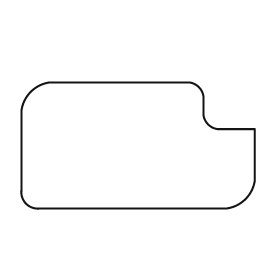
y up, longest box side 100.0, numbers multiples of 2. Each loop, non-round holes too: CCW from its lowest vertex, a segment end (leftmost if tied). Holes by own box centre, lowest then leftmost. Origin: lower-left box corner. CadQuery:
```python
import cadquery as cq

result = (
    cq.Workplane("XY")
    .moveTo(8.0, 0.0)
    .lineTo(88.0, 0.0)
    .threePointArc((96.0, 4.0), (100.0, 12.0))
    .lineTo(100.0, 34.0)
    .lineTo(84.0, 34.0)
    .threePointArc((80.0, 36.0), (78.0, 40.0))
    .lineTo(78.0, 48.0)
    .threePointArc((76.0, 52.0), (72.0, 54.0))
    .lineTo(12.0, 54.0)
    .threePointArc((4.0, 50.0), (0.0, 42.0))
    .lineTo(0.0, 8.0)
    .threePointArc((2.0, 2.0), (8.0, 0.0))
    .close()
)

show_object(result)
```